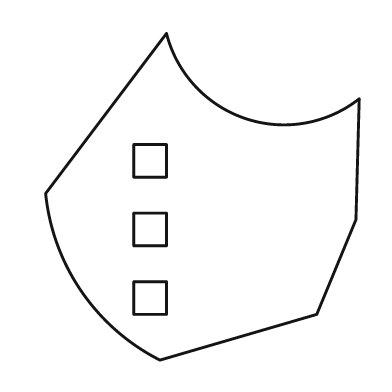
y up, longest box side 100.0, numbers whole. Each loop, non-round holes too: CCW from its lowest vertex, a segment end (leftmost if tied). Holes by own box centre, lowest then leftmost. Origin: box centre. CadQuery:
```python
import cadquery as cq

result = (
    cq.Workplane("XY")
    .moveTo(-13.0, -50.0)
    .lineTo(35.0, -36.0)
    .lineTo(47.0, -7.0)
    .lineTo(48.0, 30.0)
    .threePointArc((13.0, 24.0), (-11.0, 50.0))
    .lineTo(-48.0, 1.0)
    .threePointArc((-37.0, -29.0), (-13.0, -50.0))
    .close()
    .moveTo(-21.0, -36.0)
    .lineTo(-11.0, -36.0)
    .lineTo(-11.0, -26.0)
    .lineTo(-21.0, -26.0)
    .close()
    .moveTo(-21.0, -15.0)
    .lineTo(-11.0, -15.0)
    .lineTo(-11.0, -5.0)
    .lineTo(-21.0, -5.0)
    .close()
    .moveTo(-21.0, 6.0)
    .lineTo(-11.0, 6.0)
    .lineTo(-11.0, 16.0)
    .lineTo(-21.0, 16.0)
    .close()
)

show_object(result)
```